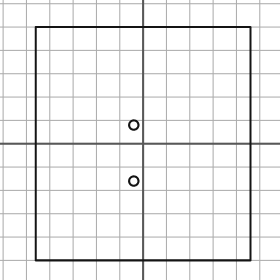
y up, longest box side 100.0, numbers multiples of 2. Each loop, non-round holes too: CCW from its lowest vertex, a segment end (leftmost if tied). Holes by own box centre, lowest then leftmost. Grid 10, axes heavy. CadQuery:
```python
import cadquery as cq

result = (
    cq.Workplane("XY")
    .moveTo(-46.0, -50.0)
    .lineTo(46.0, -50.0)
    .lineTo(46.0, 50.0)
    .lineTo(-46.0, 50.0)
    .close()
    .moveTo(-4.0, -16.0)
    .circle(2.0)
    .moveTo(-4.0, 8.0)
    .circle(2.0)
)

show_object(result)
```